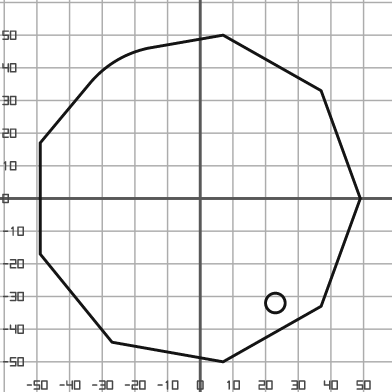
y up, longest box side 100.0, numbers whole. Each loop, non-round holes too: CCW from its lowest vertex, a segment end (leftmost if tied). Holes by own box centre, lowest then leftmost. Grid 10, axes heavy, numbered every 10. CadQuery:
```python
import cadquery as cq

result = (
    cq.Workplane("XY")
    .moveTo(7.0, -50.0)
    .lineTo(37.0, -33.0)
    .lineTo(49.0, 0.0)
    .lineTo(37.0, 33.0)
    .lineTo(7.0, 50.0)
    .lineTo(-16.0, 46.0)
    .threePointArc((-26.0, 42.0), (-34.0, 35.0))
    .lineTo(-49.0, 17.0)
    .lineTo(-49.0, -17.0)
    .lineTo(-27.0, -44.0)
    .close()
    .moveTo(23.0, -32.0)
    .circle(3.0)
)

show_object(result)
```